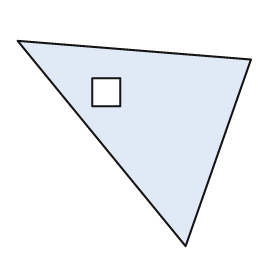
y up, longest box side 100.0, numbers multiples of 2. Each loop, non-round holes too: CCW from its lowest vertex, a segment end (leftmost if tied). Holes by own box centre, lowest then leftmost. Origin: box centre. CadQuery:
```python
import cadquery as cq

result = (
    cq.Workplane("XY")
    .moveTo(22.0, -44.0)
    .lineTo(50.0, 36.0)
    .lineTo(-50.0, 44.0)
    .close()
    .moveTo(-18.0, 16.0)
    .lineTo(-6.0, 16.0)
    .lineTo(-6.0, 28.0)
    .lineTo(-18.0, 28.0)
    .close()
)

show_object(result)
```